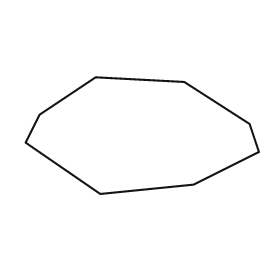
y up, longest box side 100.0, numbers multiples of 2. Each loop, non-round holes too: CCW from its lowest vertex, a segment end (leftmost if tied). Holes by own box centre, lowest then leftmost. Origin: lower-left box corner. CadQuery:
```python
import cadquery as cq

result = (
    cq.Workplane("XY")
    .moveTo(32.0, 0.0)
    .lineTo(72.0, 4.0)
    .lineTo(100.0, 18.0)
    .lineTo(96.0, 30.0)
    .lineTo(68.0, 48.0)
    .lineTo(30.0, 50.0)
    .lineTo(6.0, 34.0)
    .lineTo(0.0, 22.0)
    .close()
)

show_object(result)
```